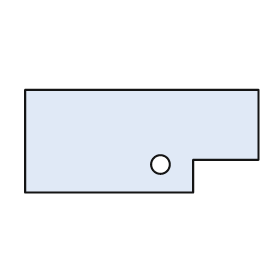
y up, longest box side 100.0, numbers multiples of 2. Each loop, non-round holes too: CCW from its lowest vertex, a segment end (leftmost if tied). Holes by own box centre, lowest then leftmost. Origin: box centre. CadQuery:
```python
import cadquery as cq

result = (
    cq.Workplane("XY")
    .moveTo(-50.0, -22.0)
    .lineTo(22.0, -22.0)
    .lineTo(22.0, -8.0)
    .lineTo(50.0, -8.0)
    .lineTo(50.0, 22.0)
    .lineTo(-50.0, 22.0)
    .close()
    .moveTo(8.0, -10.0)
    .circle(4.0)
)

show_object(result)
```